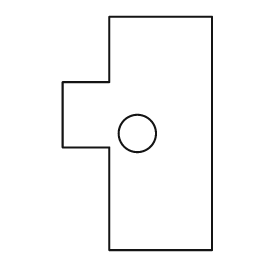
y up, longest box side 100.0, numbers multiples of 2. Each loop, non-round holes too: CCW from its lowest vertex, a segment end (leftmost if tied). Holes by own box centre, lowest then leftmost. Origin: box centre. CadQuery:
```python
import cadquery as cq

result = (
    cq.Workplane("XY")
    .moveTo(-12.0, -50.0)
    .lineTo(32.0, -50.0)
    .lineTo(32.0, 50.0)
    .lineTo(-12.0, 50.0)
    .lineTo(-12.0, 22.0)
    .lineTo(-32.0, 22.0)
    .lineTo(-32.0, -6.0)
    .lineTo(-12.0, -6.0)
    .close()
    .moveTo(0.0, 0.0)
    .circle(8.0)
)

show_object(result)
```